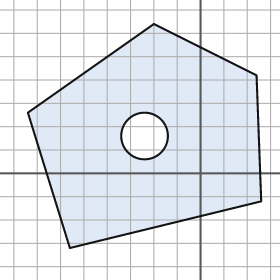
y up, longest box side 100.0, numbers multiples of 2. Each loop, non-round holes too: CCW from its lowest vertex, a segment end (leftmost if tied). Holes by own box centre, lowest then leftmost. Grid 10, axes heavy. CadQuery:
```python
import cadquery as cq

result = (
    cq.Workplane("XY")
    .moveTo(-56.0, -32.0)
    .lineTo(26.0, -12.0)
    .lineTo(24.0, 42.0)
    .lineTo(-20.0, 64.0)
    .lineTo(-74.0, 26.0)
    .close()
    .moveTo(-24.0, 16.0)
    .circle(10.0)
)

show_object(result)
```